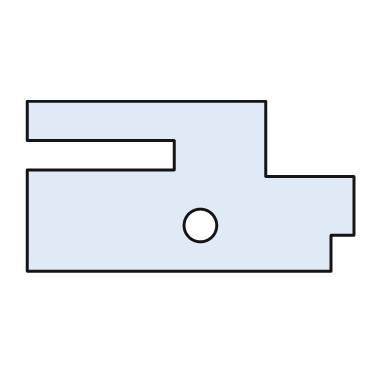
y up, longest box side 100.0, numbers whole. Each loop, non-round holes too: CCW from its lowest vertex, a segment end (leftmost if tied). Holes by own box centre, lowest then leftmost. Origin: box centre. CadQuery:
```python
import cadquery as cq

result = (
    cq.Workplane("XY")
    .moveTo(-50.0, -26.0)
    .lineTo(43.0, -26.0)
    .lineTo(43.0, -15.0)
    .lineTo(50.0, -15.0)
    .lineTo(50.0, 3.0)
    .lineTo(23.0, 3.0)
    .lineTo(23.0, 26.0)
    .lineTo(-50.0, 26.0)
    .lineTo(-50.0, 14.0)
    .lineTo(-5.0, 14.0)
    .lineTo(-5.0, 5.0)
    .lineTo(-50.0, 5.0)
    .close()
    .moveTo(3.0, -12.0)
    .circle(5.0)
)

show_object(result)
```